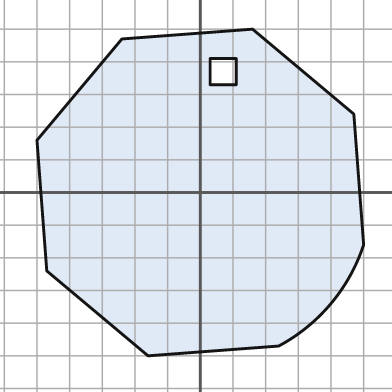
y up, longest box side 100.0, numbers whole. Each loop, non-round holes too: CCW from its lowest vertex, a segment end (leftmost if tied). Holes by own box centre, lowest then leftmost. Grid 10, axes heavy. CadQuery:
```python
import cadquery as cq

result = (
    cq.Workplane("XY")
    .moveTo(-16.0, -50.0)
    .lineTo(24.0, -47.0)
    .threePointArc((40.0, -34.0), (50.0, -16.0))
    .lineTo(47.0, 24.0)
    .lineTo(16.0, 50.0)
    .lineTo(-24.0, 47.0)
    .lineTo(-50.0, 16.0)
    .lineTo(-47.0, -24.0)
    .close()
    .moveTo(3.0, 33.0)
    .lineTo(11.0, 33.0)
    .lineTo(11.0, 41.0)
    .lineTo(3.0, 41.0)
    .close()
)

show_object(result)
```